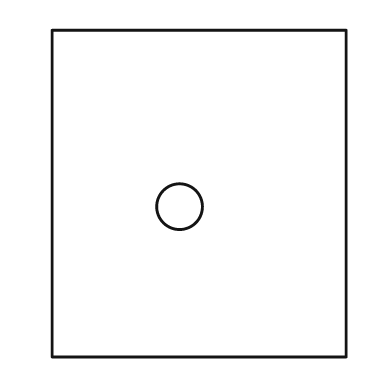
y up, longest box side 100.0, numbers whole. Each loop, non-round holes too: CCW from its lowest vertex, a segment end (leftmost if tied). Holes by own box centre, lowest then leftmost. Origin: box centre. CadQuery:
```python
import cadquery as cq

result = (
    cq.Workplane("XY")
    .moveTo(-45.0, -50.0)
    .lineTo(45.0, -50.0)
    .lineTo(45.0, 50.0)
    .lineTo(-45.0, 50.0)
    .close()
    .moveTo(-6.0, -4.0)
    .circle(7.0)
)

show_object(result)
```